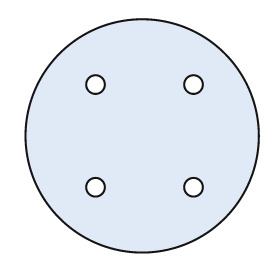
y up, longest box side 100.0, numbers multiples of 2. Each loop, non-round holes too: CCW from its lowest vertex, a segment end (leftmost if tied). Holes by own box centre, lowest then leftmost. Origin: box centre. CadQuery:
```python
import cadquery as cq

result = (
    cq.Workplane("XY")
    .moveTo(0.0, 0.0)
    .circle(50.0)
    .moveTo(-20.0, -22.0)
    .circle(4.0)
    .moveTo(22.0, -22.0)
    .circle(4.0)
    .moveTo(-20.0, 22.0)
    .circle(4.0)
    .moveTo(22.0, 22.0)
    .circle(4.0)
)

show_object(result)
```